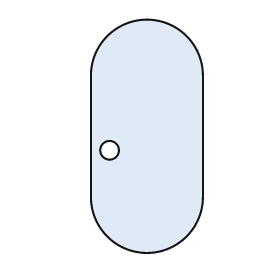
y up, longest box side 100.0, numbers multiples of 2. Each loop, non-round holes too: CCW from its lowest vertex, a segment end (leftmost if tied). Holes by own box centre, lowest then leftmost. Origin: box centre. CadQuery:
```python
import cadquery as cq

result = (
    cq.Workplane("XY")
    .moveTo(-24.0, -26.0)
    .threePointArc((0.0, -50.0), (24.0, -26.0))
    .lineTo(24.0, 26.0)
    .threePointArc((0.0, 50.0), (-24.0, 26.0))
    .close()
    .moveTo(-16.0, -6.0)
    .circle(4.0)
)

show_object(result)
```